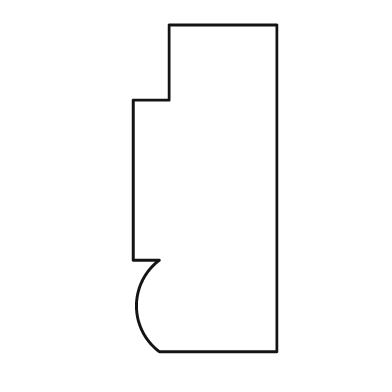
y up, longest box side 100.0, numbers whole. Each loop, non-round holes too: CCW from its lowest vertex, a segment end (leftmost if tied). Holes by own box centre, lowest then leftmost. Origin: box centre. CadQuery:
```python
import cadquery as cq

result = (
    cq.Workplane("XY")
    .moveTo(-14.0, -50.0)
    .lineTo(22.0, -50.0)
    .lineTo(22.0, 50.0)
    .lineTo(-11.0, 50.0)
    .lineTo(-11.0, 27.0)
    .lineTo(-22.0, 27.0)
    .lineTo(-22.0, -22.0)
    .lineTo(-14.0, -22.0)
    .threePointArc((-21.0, -36.0), (-14.0, -50.0))
    .close()
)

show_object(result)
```